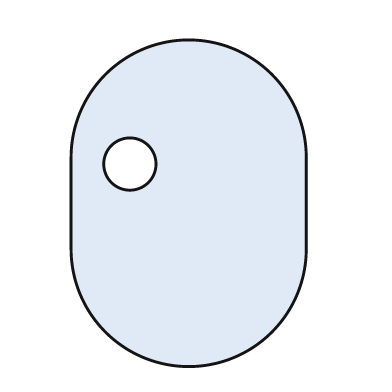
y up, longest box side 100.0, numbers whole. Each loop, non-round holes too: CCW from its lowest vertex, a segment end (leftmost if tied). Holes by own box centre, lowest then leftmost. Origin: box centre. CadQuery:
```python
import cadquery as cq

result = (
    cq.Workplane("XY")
    .moveTo(-36.0, -14.0)
    .threePointArc((0.0, -50.0), (36.0, -14.0))
    .lineTo(36.0, 14.0)
    .threePointArc((0.0, 50.0), (-36.0, 14.0))
    .close()
    .moveTo(-18.0, 12.0)
    .circle(8.0)
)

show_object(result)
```